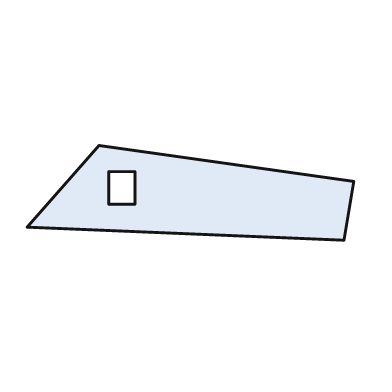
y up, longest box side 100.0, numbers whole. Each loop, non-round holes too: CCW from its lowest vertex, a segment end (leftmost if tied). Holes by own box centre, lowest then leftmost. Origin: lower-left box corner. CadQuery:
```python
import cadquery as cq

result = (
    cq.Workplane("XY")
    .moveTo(97.0, 0.0)
    .lineTo(100.0, 18.0)
    .lineTo(22.0, 29.0)
    .lineTo(0.0, 4.0)
    .close()
    .moveTo(25.0, 11.0)
    .lineTo(33.0, 11.0)
    .lineTo(33.0, 21.0)
    .lineTo(25.0, 21.0)
    .close()
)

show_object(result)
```